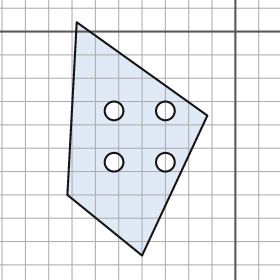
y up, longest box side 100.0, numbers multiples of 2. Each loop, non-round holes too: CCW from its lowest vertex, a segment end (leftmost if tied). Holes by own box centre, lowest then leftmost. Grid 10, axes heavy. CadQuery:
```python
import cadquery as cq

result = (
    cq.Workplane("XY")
    .moveTo(-40.0, -96.0)
    .lineTo(-12.0, -36.0)
    .lineTo(-68.0, 4.0)
    .lineTo(-72.0, -70.0)
    .close()
    .moveTo(-52.0, -56.0)
    .circle(4.0)
    .moveTo(-30.0, -56.0)
    .circle(4.0)
    .moveTo(-52.0, -34.0)
    .circle(4.0)
    .moveTo(-30.0, -34.0)
    .circle(4.0)
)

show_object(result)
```